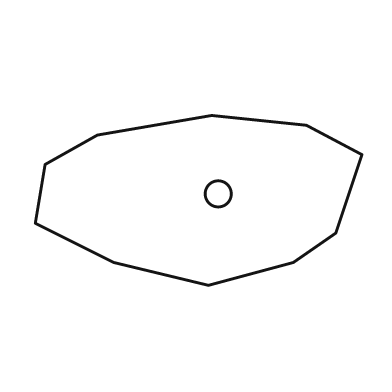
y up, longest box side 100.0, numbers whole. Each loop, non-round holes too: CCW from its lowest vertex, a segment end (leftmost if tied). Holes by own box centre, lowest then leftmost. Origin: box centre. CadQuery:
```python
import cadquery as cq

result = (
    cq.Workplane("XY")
    .moveTo(3.0, -26.0)
    .lineTo(29.0, -19.0)
    .lineTo(42.0, -10.0)
    .lineTo(50.0, 14.0)
    .lineTo(33.0, 23.0)
    .lineTo(4.0, 26.0)
    .lineTo(-31.0, 20.0)
    .lineTo(-47.0, 11.0)
    .lineTo(-50.0, -7.0)
    .lineTo(-26.0, -19.0)
    .close()
    .moveTo(6.0, 2.0)
    .circle(4.0)
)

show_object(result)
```